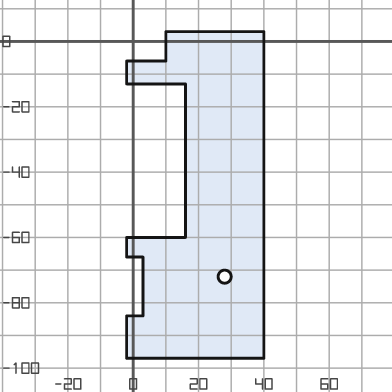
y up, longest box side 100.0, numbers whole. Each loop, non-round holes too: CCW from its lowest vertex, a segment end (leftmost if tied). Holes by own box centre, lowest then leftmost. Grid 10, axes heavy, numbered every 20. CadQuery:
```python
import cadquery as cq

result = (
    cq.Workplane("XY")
    .moveTo(-2.0, -97.0)
    .lineTo(40.0, -97.0)
    .lineTo(40.0, 3.0)
    .lineTo(10.0, 3.0)
    .lineTo(10.0, -6.0)
    .lineTo(-2.0, -6.0)
    .lineTo(-2.0, -13.0)
    .lineTo(16.0, -13.0)
    .lineTo(16.0, -60.0)
    .lineTo(-2.0, -60.0)
    .lineTo(-2.0, -66.0)
    .lineTo(3.0, -66.0)
    .lineTo(3.0, -84.0)
    .lineTo(-2.0, -84.0)
    .close()
    .moveTo(28.0, -72.0)
    .circle(2.0)
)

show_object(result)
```